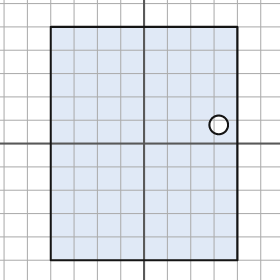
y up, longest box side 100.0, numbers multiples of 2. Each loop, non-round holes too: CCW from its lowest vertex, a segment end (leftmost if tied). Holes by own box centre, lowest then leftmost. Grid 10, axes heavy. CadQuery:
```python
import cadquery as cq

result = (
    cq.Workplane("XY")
    .moveTo(-40.0, -50.0)
    .lineTo(40.0, -50.0)
    .lineTo(40.0, 50.0)
    .lineTo(-40.0, 50.0)
    .close()
    .moveTo(32.0, 8.0)
    .circle(4.0)
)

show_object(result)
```